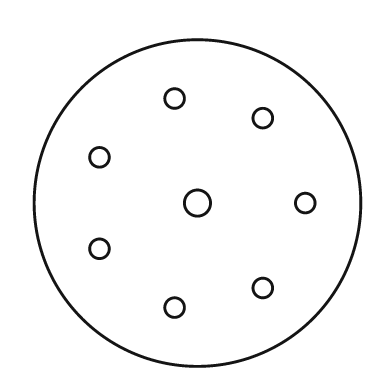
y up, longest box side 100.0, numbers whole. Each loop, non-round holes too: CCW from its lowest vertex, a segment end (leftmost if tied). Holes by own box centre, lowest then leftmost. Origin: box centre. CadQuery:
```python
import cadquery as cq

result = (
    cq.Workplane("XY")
    .moveTo(0.0, 0.0)
    .circle(50.0)
    .moveTo(-7.0, -32.0)
    .circle(3.0)
    .moveTo(20.0, -26.0)
    .circle(3.0)
    .moveTo(-30.0, -14.0)
    .circle(3.0)
    .moveTo(0.0, 0.0)
    .circle(4.0)
    .moveTo(33.0, 0.0)
    .circle(3.0)
    .moveTo(-30.0, 14.0)
    .circle(3.0)
    .moveTo(20.0, 26.0)
    .circle(3.0)
    .moveTo(-7.0, 32.0)
    .circle(3.0)
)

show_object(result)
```